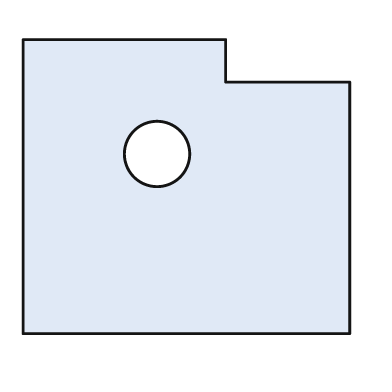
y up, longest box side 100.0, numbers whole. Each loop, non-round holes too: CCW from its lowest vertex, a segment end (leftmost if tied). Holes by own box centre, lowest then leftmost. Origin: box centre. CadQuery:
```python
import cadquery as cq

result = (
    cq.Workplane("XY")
    .moveTo(-50.0, -45.0)
    .lineTo(50.0, -45.0)
    .lineTo(50.0, 32.0)
    .lineTo(12.0, 32.0)
    .lineTo(12.0, 45.0)
    .lineTo(-50.0, 45.0)
    .close()
    .moveTo(-9.0, 10.0)
    .circle(10.0)
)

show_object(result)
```